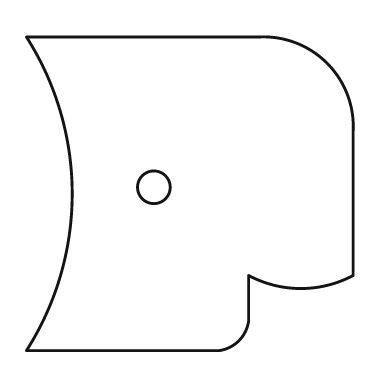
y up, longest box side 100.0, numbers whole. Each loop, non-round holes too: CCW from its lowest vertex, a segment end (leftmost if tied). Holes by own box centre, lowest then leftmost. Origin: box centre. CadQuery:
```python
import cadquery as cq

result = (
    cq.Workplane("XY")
    .moveTo(-50.0, -48.0)
    .lineTo(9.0, -48.0)
    .threePointArc((15.0, -45.0), (18.0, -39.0))
    .lineTo(18.0, -25.0)
    .threePointArc((34.0, -29.0), (50.0, -25.0))
    .lineTo(50.0, 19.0)
    .threePointArc((42.0, 40.0), (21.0, 48.0))
    .lineTo(-50.0, 48.0)
    .threePointArc((-36.0, 0.0), (-50.0, -48.0))
    .close()
    .moveTo(-11.0, 2.0)
    .circle(5.0)
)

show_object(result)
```